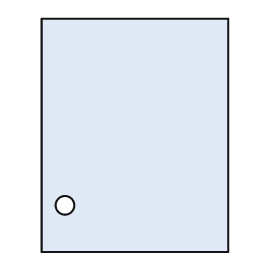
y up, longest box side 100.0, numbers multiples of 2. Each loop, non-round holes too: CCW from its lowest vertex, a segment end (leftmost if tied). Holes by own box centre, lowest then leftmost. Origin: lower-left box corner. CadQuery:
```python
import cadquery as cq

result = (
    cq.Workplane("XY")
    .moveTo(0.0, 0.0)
    .lineTo(80.0, 0.0)
    .lineTo(80.0, 100.0)
    .lineTo(0.0, 100.0)
    .close()
    .moveTo(10.0, 20.0)
    .circle(4.0)
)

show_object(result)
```